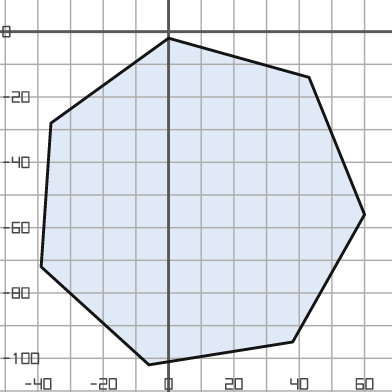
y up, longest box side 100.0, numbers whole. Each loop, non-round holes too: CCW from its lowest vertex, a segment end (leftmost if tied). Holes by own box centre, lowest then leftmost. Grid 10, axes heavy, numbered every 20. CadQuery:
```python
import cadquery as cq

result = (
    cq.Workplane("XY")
    .moveTo(-6.0, -102.0)
    .lineTo(38.0, -95.0)
    .lineTo(60.0, -56.0)
    .lineTo(43.0, -14.0)
    .lineTo(0.0, -2.0)
    .lineTo(-36.0, -28.0)
    .lineTo(-39.0, -72.0)
    .close()
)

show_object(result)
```